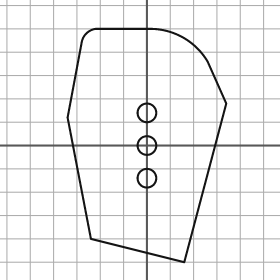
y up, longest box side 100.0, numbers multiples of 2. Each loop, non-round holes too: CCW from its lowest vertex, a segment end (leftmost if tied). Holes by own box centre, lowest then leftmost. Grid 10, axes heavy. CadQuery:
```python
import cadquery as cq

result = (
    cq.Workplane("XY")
    .moveTo(16.0, -50.0)
    .lineTo(34.0, 18.0)
    .lineTo(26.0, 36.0)
    .threePointArc((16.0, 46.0), (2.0, 50.0))
    .lineTo(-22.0, 50.0)
    .threePointArc((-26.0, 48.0), (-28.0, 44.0))
    .lineTo(-34.0, 12.0)
    .lineTo(-24.0, -40.0)
    .close()
    .moveTo(0.0, -14.0)
    .circle(4.0)
    .moveTo(0.0, 0.0)
    .circle(4.0)
    .moveTo(0.0, 14.0)
    .circle(4.0)
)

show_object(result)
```